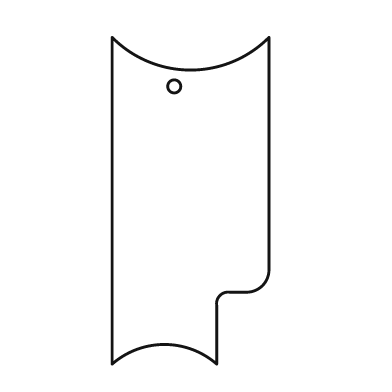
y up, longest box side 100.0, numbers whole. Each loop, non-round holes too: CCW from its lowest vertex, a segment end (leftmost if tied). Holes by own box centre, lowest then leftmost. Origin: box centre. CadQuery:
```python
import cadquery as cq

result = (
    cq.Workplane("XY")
    .moveTo(-24.0, -50.0)
    .threePointArc((-8.0, -44.0), (8.0, -50.0))
    .lineTo(8.0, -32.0)
    .threePointArc((9.0, -29.0), (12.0, -28.0))
    .lineTo(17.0, -28.0)
    .threePointArc((22.0, -26.0), (24.0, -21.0))
    .lineTo(24.0, 50.0)
    .threePointArc((0.0, 40.0), (-24.0, 50.0))
    .close()
    .moveTo(-5.0, 35.0)
    .circle(2.0)
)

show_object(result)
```